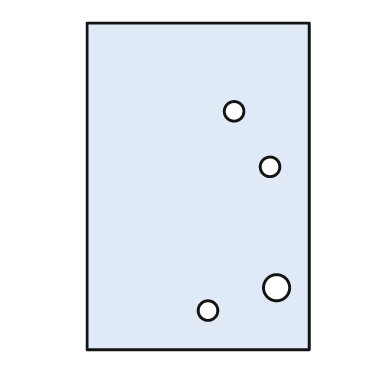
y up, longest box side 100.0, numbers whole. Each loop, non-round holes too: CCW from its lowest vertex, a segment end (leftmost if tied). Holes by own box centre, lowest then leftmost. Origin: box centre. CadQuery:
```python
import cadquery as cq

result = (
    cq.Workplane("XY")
    .moveTo(-34.0, -50.0)
    .lineTo(34.0, -50.0)
    .lineTo(34.0, 50.0)
    .lineTo(-34.0, 50.0)
    .close()
    .moveTo(3.0, -38.0)
    .circle(3.0)
    .moveTo(24.0, -31.0)
    .circle(4.0)
    .moveTo(22.0, 6.0)
    .circle(3.0)
    .moveTo(11.0, 23.0)
    .circle(3.0)
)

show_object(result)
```